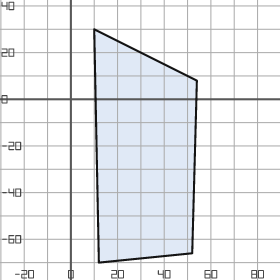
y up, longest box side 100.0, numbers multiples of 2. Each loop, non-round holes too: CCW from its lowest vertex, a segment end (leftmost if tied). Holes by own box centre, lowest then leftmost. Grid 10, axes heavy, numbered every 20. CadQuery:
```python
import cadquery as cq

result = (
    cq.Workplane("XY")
    .moveTo(12.0, -70.0)
    .lineTo(52.0, -66.0)
    .lineTo(54.0, 8.0)
    .lineTo(10.0, 30.0)
    .close()
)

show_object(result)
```